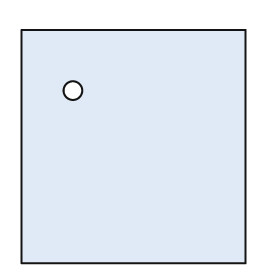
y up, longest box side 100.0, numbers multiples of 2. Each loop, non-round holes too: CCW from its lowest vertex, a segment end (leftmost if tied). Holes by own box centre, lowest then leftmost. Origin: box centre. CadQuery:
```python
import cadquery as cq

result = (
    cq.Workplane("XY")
    .moveTo(-48.0, -50.0)
    .lineTo(48.0, -50.0)
    .lineTo(48.0, 50.0)
    .lineTo(-48.0, 50.0)
    .close()
    .moveTo(-26.0, 24.0)
    .circle(4.0)
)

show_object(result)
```